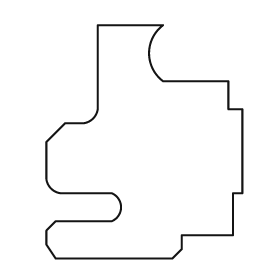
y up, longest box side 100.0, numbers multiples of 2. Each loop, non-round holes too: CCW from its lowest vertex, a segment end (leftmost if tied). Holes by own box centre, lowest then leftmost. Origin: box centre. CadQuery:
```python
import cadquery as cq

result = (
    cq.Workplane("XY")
    .moveTo(-38.0, -50.0)
    .lineTo(12.0, -50.0)
    .lineTo(16.0, -46.0)
    .lineTo(16.0, -40.0)
    .lineTo(38.0, -40.0)
    .lineTo(38.0, -22.0)
    .lineTo(42.0, -22.0)
    .lineTo(42.0, 14.0)
    .lineTo(36.0, 14.0)
    .lineTo(36.0, 26.0)
    .lineTo(8.0, 26.0)
    .threePointArc((2.0, 38.0), (8.0, 50.0))
    .lineTo(-20.0, 50.0)
    .lineTo(-20.0, 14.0)
    .threePointArc((-22.0, 10.0), (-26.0, 8.0))
    .lineTo(-34.0, 8.0)
    .lineTo(-42.0, 0.0)
    .lineTo(-42.0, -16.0)
    .threePointArc((-40.0, -20.0), (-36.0, -22.0))
    .lineTo(-14.0, -22.0)
    .threePointArc((-10.0, -28.0), (-14.0, -34.0))
    .lineTo(-38.0, -34.0)
    .lineTo(-42.0, -38.0)
    .lineTo(-42.0, -44.0)
    .close()
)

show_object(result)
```